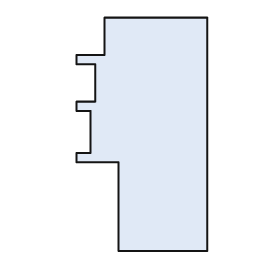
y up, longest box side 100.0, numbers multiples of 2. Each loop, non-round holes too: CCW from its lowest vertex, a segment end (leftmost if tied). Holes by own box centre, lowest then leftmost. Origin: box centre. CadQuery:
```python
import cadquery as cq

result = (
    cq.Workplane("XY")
    .moveTo(-10.0, -50.0)
    .lineTo(28.0, -50.0)
    .lineTo(28.0, 50.0)
    .lineTo(-16.0, 50.0)
    .lineTo(-16.0, 34.0)
    .lineTo(-28.0, 34.0)
    .lineTo(-28.0, 30.0)
    .lineTo(-20.0, 30.0)
    .lineTo(-20.0, 14.0)
    .lineTo(-28.0, 14.0)
    .lineTo(-28.0, 10.0)
    .lineTo(-22.0, 10.0)
    .lineTo(-22.0, -8.0)
    .lineTo(-28.0, -8.0)
    .lineTo(-28.0, -12.0)
    .lineTo(-10.0, -12.0)
    .close()
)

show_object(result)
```